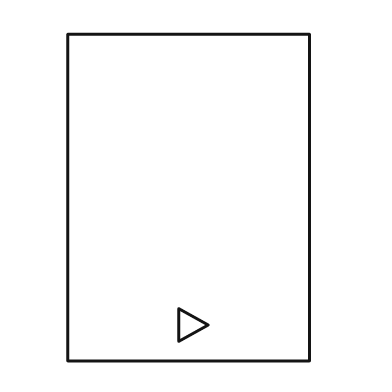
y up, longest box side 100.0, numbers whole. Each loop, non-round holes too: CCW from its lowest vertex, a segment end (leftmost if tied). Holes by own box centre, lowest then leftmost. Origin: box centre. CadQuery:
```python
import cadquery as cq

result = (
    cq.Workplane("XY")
    .moveTo(-37.0, -50.0)
    .lineTo(37.0, -50.0)
    .lineTo(37.0, 50.0)
    .lineTo(-37.0, 50.0)
    .close()
    .moveTo(-3.0, -44.0)
    .lineTo(6.0, -39.0)
    .lineTo(-3.0, -34.0)
    .close()
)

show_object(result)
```